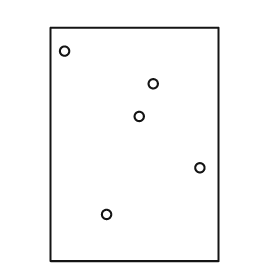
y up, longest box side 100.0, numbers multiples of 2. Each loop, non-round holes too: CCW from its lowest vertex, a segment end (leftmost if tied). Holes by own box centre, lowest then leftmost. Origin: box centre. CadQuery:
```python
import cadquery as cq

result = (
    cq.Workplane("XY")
    .moveTo(-36.0, -50.0)
    .lineTo(36.0, -50.0)
    .lineTo(36.0, 50.0)
    .lineTo(-36.0, 50.0)
    .close()
    .moveTo(-12.0, -30.0)
    .circle(2.0)
    .moveTo(28.0, -10.0)
    .circle(2.0)
    .moveTo(2.0, 12.0)
    .circle(2.0)
    .moveTo(8.0, 26.0)
    .circle(2.0)
    .moveTo(-30.0, 40.0)
    .circle(2.0)
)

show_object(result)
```